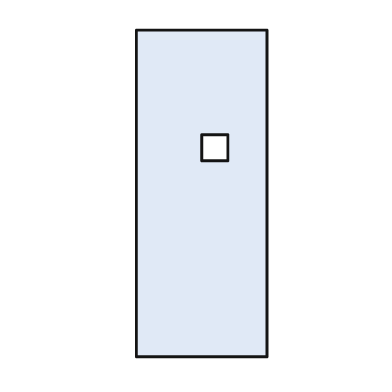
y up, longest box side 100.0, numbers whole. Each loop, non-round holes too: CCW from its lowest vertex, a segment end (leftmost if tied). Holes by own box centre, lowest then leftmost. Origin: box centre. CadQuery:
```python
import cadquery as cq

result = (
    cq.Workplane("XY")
    .moveTo(-20.0, -50.0)
    .lineTo(20.0, -50.0)
    .lineTo(20.0, 50.0)
    .lineTo(-20.0, 50.0)
    .close()
    .moveTo(0.0, 10.0)
    .lineTo(8.0, 10.0)
    .lineTo(8.0, 18.0)
    .lineTo(0.0, 18.0)
    .close()
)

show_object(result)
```